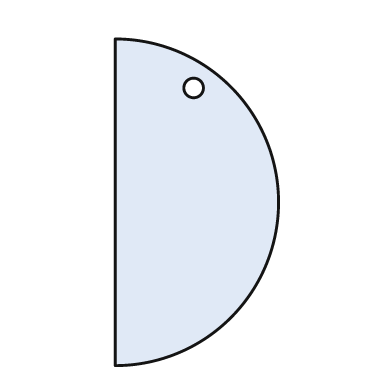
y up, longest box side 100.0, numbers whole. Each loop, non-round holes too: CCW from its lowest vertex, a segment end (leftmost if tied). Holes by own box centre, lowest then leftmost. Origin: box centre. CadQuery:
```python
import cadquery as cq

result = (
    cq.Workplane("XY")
    .moveTo(-25.0, -50.0)
    .threePointArc((25.0, 0.0), (-25.0, 50.0))
    .close()
    .moveTo(-1.0, 35.0)
    .circle(3.0)
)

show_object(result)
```